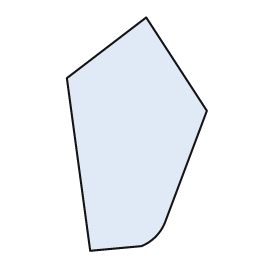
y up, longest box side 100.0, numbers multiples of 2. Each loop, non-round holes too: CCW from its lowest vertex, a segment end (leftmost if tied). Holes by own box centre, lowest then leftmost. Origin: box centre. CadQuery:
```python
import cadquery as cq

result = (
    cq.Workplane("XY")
    .moveTo(-20.0, -50.0)
    .lineTo(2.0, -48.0)
    .threePointArc((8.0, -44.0), (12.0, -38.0))
    .lineTo(30.0, 10.0)
    .lineTo(4.0, 50.0)
    .lineTo(-30.0, 24.0)
    .close()
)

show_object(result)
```